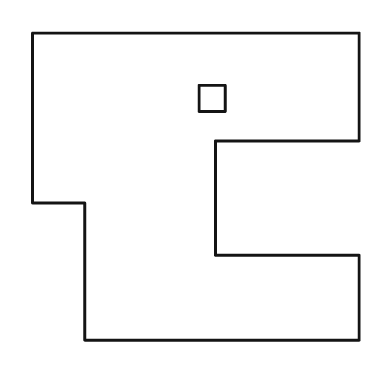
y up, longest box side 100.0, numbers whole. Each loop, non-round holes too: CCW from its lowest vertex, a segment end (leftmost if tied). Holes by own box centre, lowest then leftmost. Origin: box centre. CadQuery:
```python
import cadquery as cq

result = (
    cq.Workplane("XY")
    .moveTo(-34.0, -47.0)
    .lineTo(50.0, -47.0)
    .lineTo(50.0, -21.0)
    .lineTo(6.0, -21.0)
    .lineTo(6.0, 14.0)
    .lineTo(50.0, 14.0)
    .lineTo(50.0, 47.0)
    .lineTo(-50.0, 47.0)
    .lineTo(-50.0, -5.0)
    .lineTo(-34.0, -5.0)
    .close()
    .moveTo(1.0, 23.0)
    .lineTo(9.0, 23.0)
    .lineTo(9.0, 31.0)
    .lineTo(1.0, 31.0)
    .close()
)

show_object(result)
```